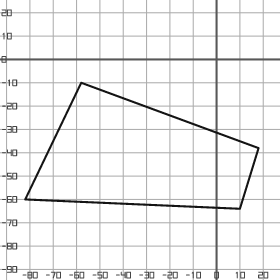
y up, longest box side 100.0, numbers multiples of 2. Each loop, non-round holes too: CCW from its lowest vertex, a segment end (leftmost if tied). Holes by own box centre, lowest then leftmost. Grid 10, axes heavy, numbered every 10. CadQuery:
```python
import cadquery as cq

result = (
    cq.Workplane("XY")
    .moveTo(10.0, -64.0)
    .lineTo(18.0, -38.0)
    .lineTo(-58.0, -10.0)
    .lineTo(-82.0, -60.0)
    .close()
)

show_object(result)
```